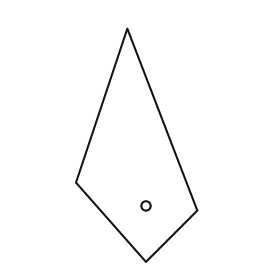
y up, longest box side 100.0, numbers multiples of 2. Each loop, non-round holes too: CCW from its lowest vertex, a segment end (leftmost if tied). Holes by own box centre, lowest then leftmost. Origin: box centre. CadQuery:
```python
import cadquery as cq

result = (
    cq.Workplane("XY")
    .moveTo(4.0, -50.0)
    .lineTo(26.0, -28.0)
    .lineTo(-4.0, 50.0)
    .lineTo(-26.0, -16.0)
    .close()
    .moveTo(4.0, -26.0)
    .circle(2.0)
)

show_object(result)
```